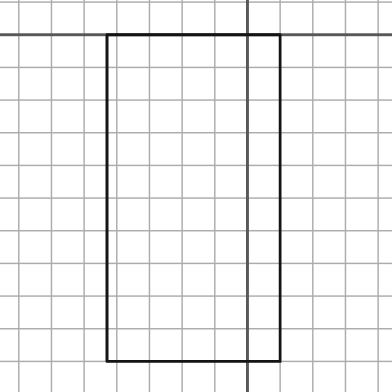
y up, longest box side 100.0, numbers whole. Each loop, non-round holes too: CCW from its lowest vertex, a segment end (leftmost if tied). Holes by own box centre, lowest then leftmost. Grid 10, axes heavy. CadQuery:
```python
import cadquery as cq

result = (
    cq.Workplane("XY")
    .moveTo(-43.0, -100.0)
    .lineTo(10.0, -100.0)
    .lineTo(10.0, 0.0)
    .lineTo(-43.0, 0.0)
    .close()
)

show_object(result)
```